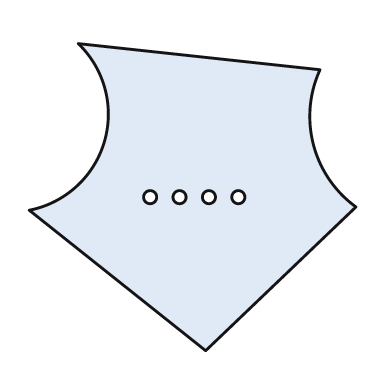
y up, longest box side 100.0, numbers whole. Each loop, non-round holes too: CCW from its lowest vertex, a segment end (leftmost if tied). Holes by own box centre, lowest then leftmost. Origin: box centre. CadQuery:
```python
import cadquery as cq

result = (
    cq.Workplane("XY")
    .moveTo(4.0, -47.0)
    .lineTo(50.0, -3.0)
    .threePointArc((37.0, 16.0), (39.0, 39.0))
    .lineTo(-35.0, 47.0)
    .threePointArc((-27.0, 17.0), (-50.0, -4.0))
    .close()
    .moveTo(-13.0, 0.0)
    .circle(2.0)
    .moveTo(-4.0, 0.0)
    .circle(2.0)
    .moveTo(5.0, 0.0)
    .circle(2.0)
    .moveTo(14.0, 0.0)
    .circle(2.0)
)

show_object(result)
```